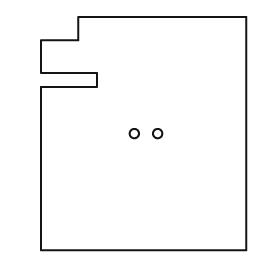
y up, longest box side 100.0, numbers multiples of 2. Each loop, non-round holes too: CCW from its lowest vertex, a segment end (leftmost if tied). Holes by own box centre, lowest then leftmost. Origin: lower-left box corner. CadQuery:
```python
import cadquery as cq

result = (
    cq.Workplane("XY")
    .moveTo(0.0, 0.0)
    .lineTo(88.0, 0.0)
    .lineTo(88.0, 100.0)
    .lineTo(16.0, 100.0)
    .lineTo(16.0, 90.0)
    .lineTo(0.0, 90.0)
    .lineTo(0.0, 76.0)
    .lineTo(24.0, 76.0)
    .lineTo(24.0, 70.0)
    .lineTo(0.0, 70.0)
    .close()
    .moveTo(40.0, 50.0)
    .circle(2.0)
    .moveTo(50.0, 50.0)
    .circle(2.0)
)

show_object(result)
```